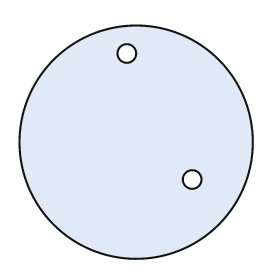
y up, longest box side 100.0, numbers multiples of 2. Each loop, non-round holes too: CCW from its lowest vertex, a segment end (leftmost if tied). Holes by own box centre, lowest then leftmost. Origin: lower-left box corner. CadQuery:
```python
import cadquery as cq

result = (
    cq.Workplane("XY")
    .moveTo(50.0, 50.0)
    .circle(50.0)
    .moveTo(74.0, 34.0)
    .circle(4.0)
    .moveTo(46.0, 88.0)
    .circle(4.0)
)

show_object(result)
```